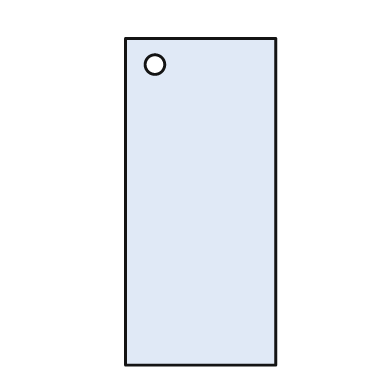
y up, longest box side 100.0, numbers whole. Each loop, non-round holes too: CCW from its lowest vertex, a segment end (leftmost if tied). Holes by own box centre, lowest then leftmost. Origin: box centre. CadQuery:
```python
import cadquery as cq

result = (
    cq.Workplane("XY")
    .moveTo(-23.0, -50.0)
    .lineTo(23.0, -50.0)
    .lineTo(23.0, 50.0)
    .lineTo(-23.0, 50.0)
    .close()
    .moveTo(-14.0, 42.0)
    .circle(3.0)
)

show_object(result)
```